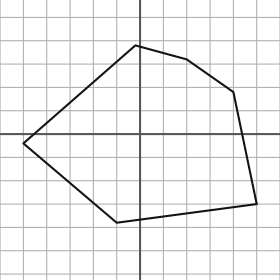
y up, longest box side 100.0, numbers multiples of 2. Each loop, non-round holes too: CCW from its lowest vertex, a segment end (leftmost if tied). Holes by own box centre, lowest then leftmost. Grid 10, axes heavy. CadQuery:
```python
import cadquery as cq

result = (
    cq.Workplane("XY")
    .moveTo(-10.0, -38.0)
    .lineTo(50.0, -30.0)
    .lineTo(40.0, 18.0)
    .lineTo(20.0, 32.0)
    .lineTo(-2.0, 38.0)
    .lineTo(-50.0, -4.0)
    .close()
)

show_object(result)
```